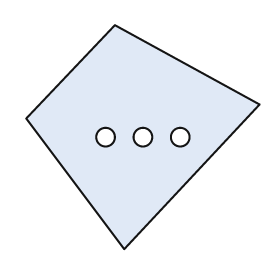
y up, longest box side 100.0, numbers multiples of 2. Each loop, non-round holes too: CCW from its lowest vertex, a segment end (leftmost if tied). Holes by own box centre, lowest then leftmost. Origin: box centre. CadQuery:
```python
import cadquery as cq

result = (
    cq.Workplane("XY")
    .moveTo(-8.0, -48.0)
    .lineTo(50.0, 14.0)
    .lineTo(-12.0, 48.0)
    .lineTo(-50.0, 8.0)
    .close()
    .moveTo(-16.0, 0.0)
    .circle(4.0)
    .moveTo(0.0, 0.0)
    .circle(4.0)
    .moveTo(16.0, 0.0)
    .circle(4.0)
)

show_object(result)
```